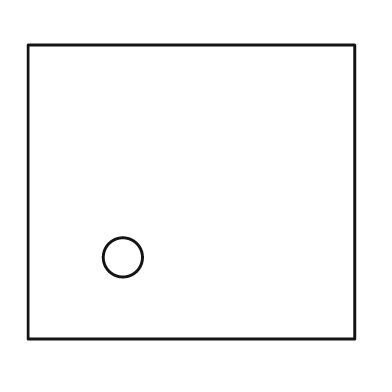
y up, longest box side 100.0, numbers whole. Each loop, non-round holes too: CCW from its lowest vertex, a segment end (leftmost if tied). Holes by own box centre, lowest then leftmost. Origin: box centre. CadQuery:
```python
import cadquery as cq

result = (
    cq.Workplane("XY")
    .moveTo(-50.0, -45.0)
    .lineTo(50.0, -45.0)
    .lineTo(50.0, 45.0)
    .lineTo(-50.0, 45.0)
    .close()
    .moveTo(-21.0, -20.0)
    .circle(6.0)
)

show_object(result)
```